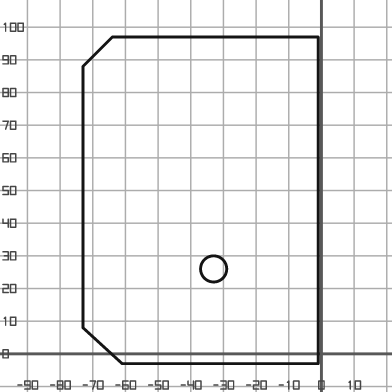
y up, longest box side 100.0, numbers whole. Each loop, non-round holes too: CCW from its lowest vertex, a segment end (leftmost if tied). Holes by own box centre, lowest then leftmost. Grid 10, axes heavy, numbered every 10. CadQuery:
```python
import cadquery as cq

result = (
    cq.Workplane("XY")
    .moveTo(-61.0, -3.0)
    .lineTo(-1.0, -3.0)
    .lineTo(-1.0, 97.0)
    .lineTo(-64.0, 97.0)
    .lineTo(-73.0, 88.0)
    .lineTo(-73.0, 8.0)
    .close()
    .moveTo(-33.0, 26.0)
    .circle(4.0)
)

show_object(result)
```